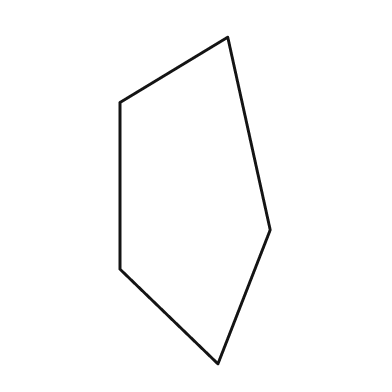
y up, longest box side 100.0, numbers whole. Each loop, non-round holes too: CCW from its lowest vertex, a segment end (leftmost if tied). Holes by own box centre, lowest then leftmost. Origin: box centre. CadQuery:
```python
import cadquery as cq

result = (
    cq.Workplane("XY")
    .moveTo(7.0, -50.0)
    .lineTo(23.0, -9.0)
    .lineTo(10.0, 50.0)
    .lineTo(-23.0, 30.0)
    .lineTo(-23.0, -21.0)
    .close()
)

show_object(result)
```